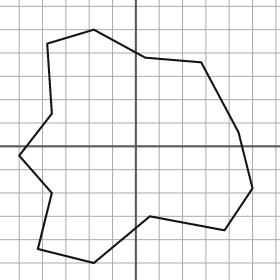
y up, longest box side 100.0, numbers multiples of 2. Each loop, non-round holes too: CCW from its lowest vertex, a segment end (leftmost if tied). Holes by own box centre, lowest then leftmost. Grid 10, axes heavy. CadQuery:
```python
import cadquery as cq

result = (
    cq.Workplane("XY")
    .moveTo(-18.0, -50.0)
    .lineTo(6.0, -30.0)
    .lineTo(38.0, -36.0)
    .lineTo(50.0, -18.0)
    .lineTo(44.0, 6.0)
    .lineTo(28.0, 36.0)
    .lineTo(4.0, 38.0)
    .lineTo(-18.0, 50.0)
    .lineTo(-38.0, 44.0)
    .lineTo(-36.0, 14.0)
    .lineTo(-50.0, -4.0)
    .lineTo(-36.0, -20.0)
    .lineTo(-42.0, -44.0)
    .close()
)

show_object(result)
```